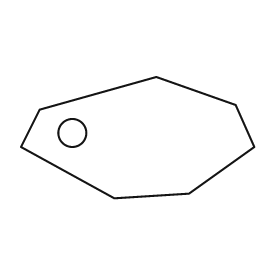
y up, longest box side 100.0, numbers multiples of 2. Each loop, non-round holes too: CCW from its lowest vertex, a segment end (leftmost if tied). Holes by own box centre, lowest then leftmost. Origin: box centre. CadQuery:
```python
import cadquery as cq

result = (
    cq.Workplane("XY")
    .moveTo(-10.0, -26.0)
    .lineTo(22.0, -24.0)
    .lineTo(50.0, -4.0)
    .lineTo(42.0, 14.0)
    .lineTo(8.0, 26.0)
    .lineTo(-42.0, 12.0)
    .lineTo(-50.0, -4.0)
    .close()
    .moveTo(-28.0, 2.0)
    .circle(6.0)
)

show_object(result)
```